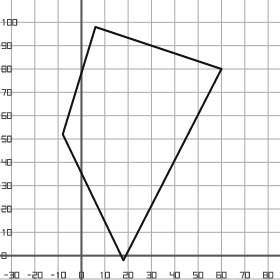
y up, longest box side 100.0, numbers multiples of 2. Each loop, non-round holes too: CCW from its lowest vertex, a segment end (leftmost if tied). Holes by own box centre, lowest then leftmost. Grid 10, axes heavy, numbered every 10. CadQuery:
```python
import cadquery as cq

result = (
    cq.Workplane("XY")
    .moveTo(18.0, -2.0)
    .lineTo(60.0, 80.0)
    .lineTo(6.0, 98.0)
    .lineTo(-8.0, 52.0)
    .close()
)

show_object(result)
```